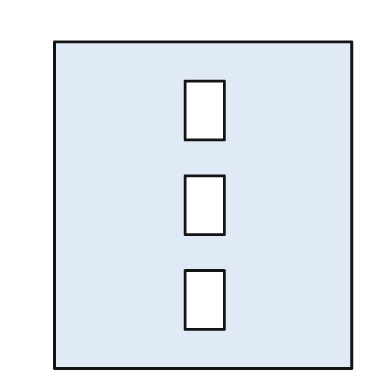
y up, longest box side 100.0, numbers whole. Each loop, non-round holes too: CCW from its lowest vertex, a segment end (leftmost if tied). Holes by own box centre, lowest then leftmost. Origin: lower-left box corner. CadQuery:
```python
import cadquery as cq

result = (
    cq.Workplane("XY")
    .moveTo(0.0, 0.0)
    .lineTo(91.0, 0.0)
    .lineTo(91.0, 100.0)
    .lineTo(0.0, 100.0)
    .close()
    .moveTo(40.0, 12.0)
    .lineTo(52.0, 12.0)
    .lineTo(52.0, 30.0)
    .lineTo(40.0, 30.0)
    .close()
    .moveTo(40.0, 41.0)
    .lineTo(52.0, 41.0)
    .lineTo(52.0, 59.0)
    .lineTo(40.0, 59.0)
    .close()
    .moveTo(40.0, 70.0)
    .lineTo(52.0, 70.0)
    .lineTo(52.0, 88.0)
    .lineTo(40.0, 88.0)
    .close()
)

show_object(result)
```